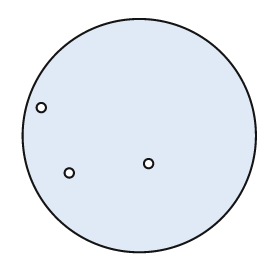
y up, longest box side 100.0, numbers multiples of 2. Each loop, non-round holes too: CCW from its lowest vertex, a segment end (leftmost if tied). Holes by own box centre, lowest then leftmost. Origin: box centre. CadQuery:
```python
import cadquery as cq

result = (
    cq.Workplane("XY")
    .moveTo(0.0, 0.0)
    .circle(50.0)
    .moveTo(-30.0, -16.0)
    .circle(2.0)
    .moveTo(4.0, -12.0)
    .circle(2.0)
    .moveTo(-42.0, 12.0)
    .circle(2.0)
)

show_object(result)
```